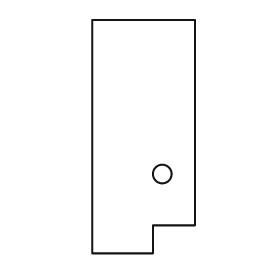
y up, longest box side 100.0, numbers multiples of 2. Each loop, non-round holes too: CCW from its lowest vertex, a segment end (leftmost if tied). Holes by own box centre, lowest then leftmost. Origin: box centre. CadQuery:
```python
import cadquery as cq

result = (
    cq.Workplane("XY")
    .moveTo(-22.0, -50.0)
    .lineTo(4.0, -50.0)
    .lineTo(4.0, -38.0)
    .lineTo(22.0, -38.0)
    .lineTo(22.0, 50.0)
    .lineTo(-22.0, 50.0)
    .close()
    .moveTo(8.0, -16.0)
    .circle(4.0)
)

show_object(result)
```